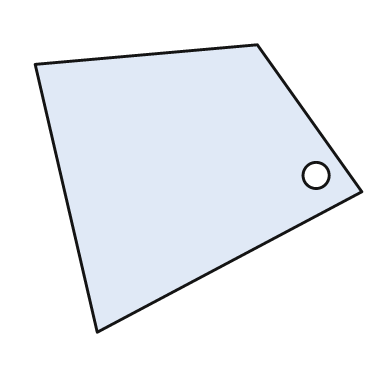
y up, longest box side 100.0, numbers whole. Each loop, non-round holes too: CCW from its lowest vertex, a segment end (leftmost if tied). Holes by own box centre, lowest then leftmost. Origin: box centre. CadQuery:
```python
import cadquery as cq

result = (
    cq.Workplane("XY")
    .moveTo(-31.0, -44.0)
    .lineTo(50.0, -1.0)
    .lineTo(18.0, 44.0)
    .lineTo(-50.0, 38.0)
    .close()
    .moveTo(36.0, 4.0)
    .circle(4.0)
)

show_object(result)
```